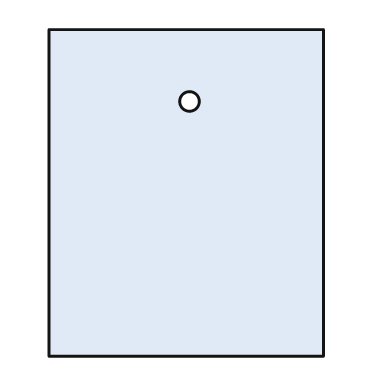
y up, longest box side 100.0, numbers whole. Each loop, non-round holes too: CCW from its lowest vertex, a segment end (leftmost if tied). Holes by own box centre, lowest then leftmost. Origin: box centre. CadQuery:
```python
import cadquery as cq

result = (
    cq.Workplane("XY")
    .moveTo(-42.0, -50.0)
    .lineTo(42.0, -50.0)
    .lineTo(42.0, 50.0)
    .lineTo(-42.0, 50.0)
    .close()
    .moveTo(1.0, 28.0)
    .circle(3.0)
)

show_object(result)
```